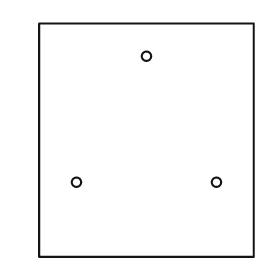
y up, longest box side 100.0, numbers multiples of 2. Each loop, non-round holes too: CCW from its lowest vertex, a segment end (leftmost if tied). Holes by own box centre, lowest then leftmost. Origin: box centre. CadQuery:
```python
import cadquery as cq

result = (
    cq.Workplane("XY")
    .moveTo(-46.0, -50.0)
    .lineTo(46.0, -50.0)
    .lineTo(46.0, 50.0)
    .lineTo(-46.0, 50.0)
    .close()
    .moveTo(-30.0, -18.0)
    .circle(2.0)
    .moveTo(30.0, -18.0)
    .circle(2.0)
    .moveTo(0.0, 36.0)
    .circle(2.0)
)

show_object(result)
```